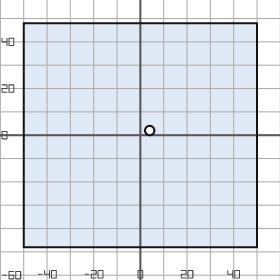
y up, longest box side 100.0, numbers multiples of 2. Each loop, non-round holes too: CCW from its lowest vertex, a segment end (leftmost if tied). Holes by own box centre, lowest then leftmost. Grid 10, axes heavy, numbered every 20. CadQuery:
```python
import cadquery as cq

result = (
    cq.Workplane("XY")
    .moveTo(-50.0, -48.0)
    .lineTo(50.0, -48.0)
    .lineTo(50.0, 48.0)
    .lineTo(-50.0, 48.0)
    .close()
    .moveTo(4.0, 2.0)
    .circle(2.0)
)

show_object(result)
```